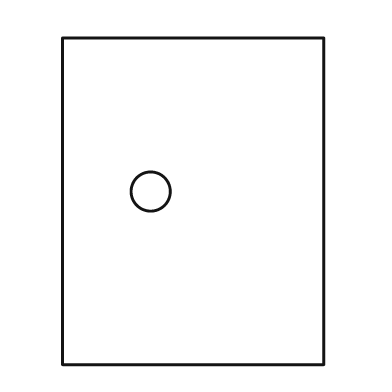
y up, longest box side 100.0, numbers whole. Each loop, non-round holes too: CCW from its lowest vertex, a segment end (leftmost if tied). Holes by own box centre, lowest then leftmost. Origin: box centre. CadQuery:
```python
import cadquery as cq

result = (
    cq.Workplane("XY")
    .moveTo(-40.0, -50.0)
    .lineTo(40.0, -50.0)
    .lineTo(40.0, 50.0)
    .lineTo(-40.0, 50.0)
    .close()
    .moveTo(-13.0, 3.0)
    .circle(6.0)
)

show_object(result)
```